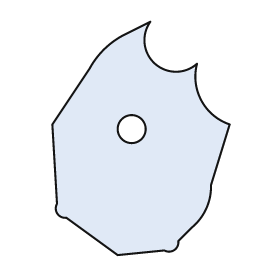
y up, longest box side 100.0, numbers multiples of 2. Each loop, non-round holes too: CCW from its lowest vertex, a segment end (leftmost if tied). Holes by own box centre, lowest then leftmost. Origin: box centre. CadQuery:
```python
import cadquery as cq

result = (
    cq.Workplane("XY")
    .moveTo(-10.0, -50.0)
    .lineTo(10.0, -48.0)
    .threePointArc((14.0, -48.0), (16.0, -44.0))
    .lineTo(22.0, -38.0)
    .threePointArc((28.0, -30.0), (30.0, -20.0))
    .lineTo(38.0, 6.0)
    .threePointArc((26.0, 16.0), (24.0, 32.0))
    .threePointArc((6.0, 32.0), (4.0, 50.0))
    .lineTo(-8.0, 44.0)
    .threePointArc((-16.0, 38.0), (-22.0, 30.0))
    .lineTo(-38.0, 6.0)
    .lineTo(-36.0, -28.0)
    .threePointArc((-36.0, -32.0), (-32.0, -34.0))
    .close()
    .moveTo(-4.0, 4.0)
    .circle(6.0)
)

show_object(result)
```